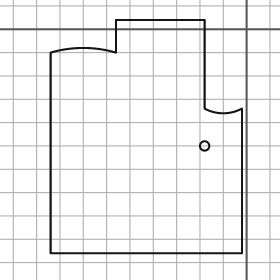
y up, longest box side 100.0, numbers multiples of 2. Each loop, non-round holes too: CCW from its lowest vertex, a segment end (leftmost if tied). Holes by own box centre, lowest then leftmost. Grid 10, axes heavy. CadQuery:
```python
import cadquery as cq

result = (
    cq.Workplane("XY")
    .moveTo(-84.0, -96.0)
    .lineTo(-2.0, -96.0)
    .lineTo(-2.0, -34.0)
    .threePointArc((-10.0, -36.0), (-18.0, -34.0))
    .lineTo(-18.0, 4.0)
    .lineTo(-56.0, 4.0)
    .lineTo(-56.0, -10.0)
    .threePointArc((-70.0, -8.0), (-84.0, -10.0))
    .close()
    .moveTo(-18.0, -50.0)
    .circle(2.0)
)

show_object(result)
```